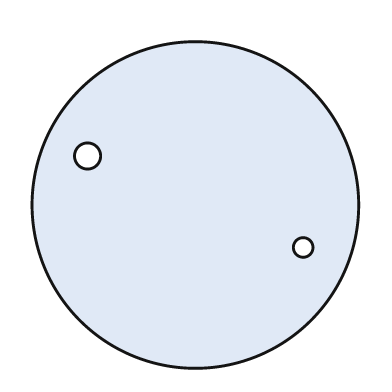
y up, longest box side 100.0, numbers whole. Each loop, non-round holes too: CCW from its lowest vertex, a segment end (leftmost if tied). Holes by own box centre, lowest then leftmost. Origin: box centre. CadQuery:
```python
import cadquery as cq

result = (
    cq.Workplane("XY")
    .moveTo(0.0, 0.0)
    .circle(50.0)
    .moveTo(33.0, -13.0)
    .circle(3.0)
    .moveTo(-33.0, 15.0)
    .circle(4.0)
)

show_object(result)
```